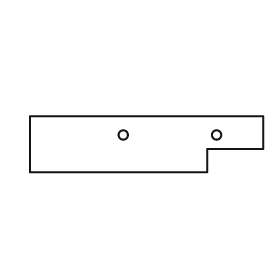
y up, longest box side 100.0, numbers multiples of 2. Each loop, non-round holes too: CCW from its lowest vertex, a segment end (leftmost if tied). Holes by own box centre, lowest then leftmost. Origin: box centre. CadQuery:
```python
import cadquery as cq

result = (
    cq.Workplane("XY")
    .moveTo(-50.0, -12.0)
    .lineTo(26.0, -12.0)
    .lineTo(26.0, -2.0)
    .lineTo(50.0, -2.0)
    .lineTo(50.0, 12.0)
    .lineTo(-50.0, 12.0)
    .close()
    .moveTo(-10.0, 4.0)
    .circle(2.0)
    .moveTo(30.0, 4.0)
    .circle(2.0)
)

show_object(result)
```